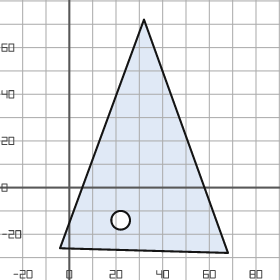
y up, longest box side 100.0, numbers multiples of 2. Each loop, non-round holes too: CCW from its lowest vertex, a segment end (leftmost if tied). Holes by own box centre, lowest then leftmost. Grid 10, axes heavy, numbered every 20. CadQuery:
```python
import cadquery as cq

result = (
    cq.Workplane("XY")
    .moveTo(68.0, -28.0)
    .lineTo(32.0, 72.0)
    .lineTo(-4.0, -26.0)
    .close()
    .moveTo(22.0, -14.0)
    .circle(4.0)
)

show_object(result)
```